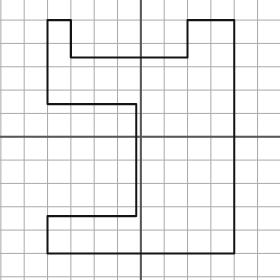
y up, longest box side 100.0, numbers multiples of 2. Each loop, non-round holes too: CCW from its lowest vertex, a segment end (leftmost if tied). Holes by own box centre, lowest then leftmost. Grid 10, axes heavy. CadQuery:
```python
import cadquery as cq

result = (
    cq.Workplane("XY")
    .moveTo(-40.0, -50.0)
    .lineTo(40.0, -50.0)
    .lineTo(40.0, 50.0)
    .lineTo(20.0, 50.0)
    .lineTo(20.0, 34.0)
    .lineTo(-30.0, 34.0)
    .lineTo(-30.0, 50.0)
    .lineTo(-40.0, 50.0)
    .lineTo(-40.0, 14.0)
    .lineTo(-2.0, 14.0)
    .lineTo(-2.0, -34.0)
    .lineTo(-40.0, -34.0)
    .close()
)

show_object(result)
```